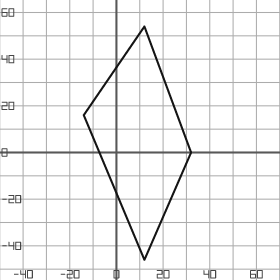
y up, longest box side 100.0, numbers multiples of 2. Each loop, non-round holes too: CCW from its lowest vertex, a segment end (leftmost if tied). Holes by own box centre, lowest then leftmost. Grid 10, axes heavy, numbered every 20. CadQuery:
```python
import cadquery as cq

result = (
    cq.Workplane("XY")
    .moveTo(12.0, -46.0)
    .lineTo(32.0, 0.0)
    .lineTo(12.0, 54.0)
    .lineTo(-14.0, 16.0)
    .close()
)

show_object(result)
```